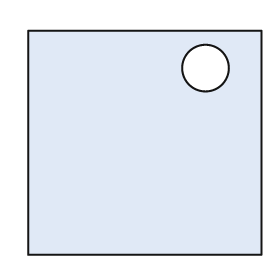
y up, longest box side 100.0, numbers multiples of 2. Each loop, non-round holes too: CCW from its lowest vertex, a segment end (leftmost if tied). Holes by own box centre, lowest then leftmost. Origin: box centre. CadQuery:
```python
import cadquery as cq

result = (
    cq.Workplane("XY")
    .moveTo(-50.0, -48.0)
    .lineTo(50.0, -48.0)
    .lineTo(50.0, 48.0)
    .lineTo(-50.0, 48.0)
    .close()
    .moveTo(26.0, 32.0)
    .circle(10.0)
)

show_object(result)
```